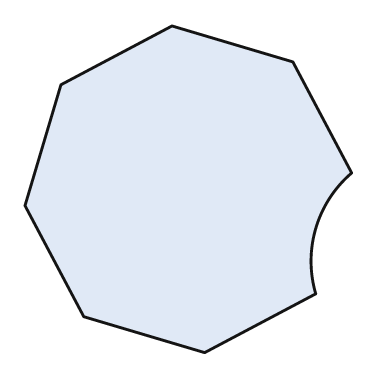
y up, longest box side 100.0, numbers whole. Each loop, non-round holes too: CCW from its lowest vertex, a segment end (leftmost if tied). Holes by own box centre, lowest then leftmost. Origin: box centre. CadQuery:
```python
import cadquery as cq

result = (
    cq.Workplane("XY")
    .moveTo(5.0, -50.0)
    .lineTo(39.0, -32.0)
    .threePointArc((39.0, -12.0), (50.0, 5.0))
    .lineTo(32.0, 39.0)
    .lineTo(-5.0, 50.0)
    .lineTo(-39.0, 32.0)
    .lineTo(-50.0, -5.0)
    .lineTo(-32.0, -39.0)
    .close()
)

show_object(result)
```